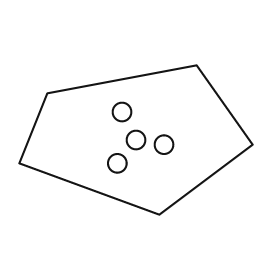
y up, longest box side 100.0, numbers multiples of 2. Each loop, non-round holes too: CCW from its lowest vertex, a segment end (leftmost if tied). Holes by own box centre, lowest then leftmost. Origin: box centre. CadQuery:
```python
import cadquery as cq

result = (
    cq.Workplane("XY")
    .moveTo(10.0, -32.0)
    .lineTo(50.0, -2.0)
    .lineTo(26.0, 32.0)
    .lineTo(-38.0, 20.0)
    .lineTo(-50.0, -10.0)
    .close()
    .moveTo(-8.0, -10.0)
    .circle(4.0)
    .moveTo(12.0, -2.0)
    .circle(4.0)
    .moveTo(0.0, 0.0)
    .circle(4.0)
    .moveTo(-6.0, 12.0)
    .circle(4.0)
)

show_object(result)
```